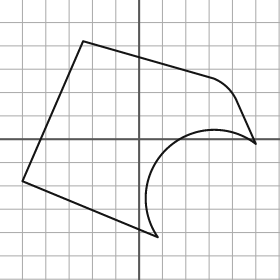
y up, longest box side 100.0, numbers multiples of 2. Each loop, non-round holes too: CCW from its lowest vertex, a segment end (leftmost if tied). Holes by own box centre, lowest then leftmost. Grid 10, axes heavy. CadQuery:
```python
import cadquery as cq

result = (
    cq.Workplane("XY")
    .moveTo(8.0, -42.0)
    .threePointArc((12.0, -4.0), (50.0, -2.0))
    .lineTo(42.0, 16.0)
    .threePointArc((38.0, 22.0), (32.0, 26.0))
    .lineTo(-24.0, 42.0)
    .lineTo(-50.0, -18.0)
    .close()
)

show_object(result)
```